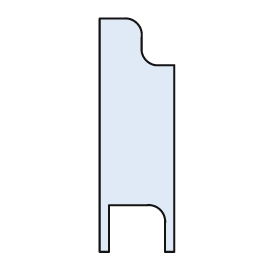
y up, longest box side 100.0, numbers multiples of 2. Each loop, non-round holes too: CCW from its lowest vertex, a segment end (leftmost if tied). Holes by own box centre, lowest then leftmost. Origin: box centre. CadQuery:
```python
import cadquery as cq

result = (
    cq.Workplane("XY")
    .moveTo(-16.0, -50.0)
    .lineTo(-12.0, -50.0)
    .lineTo(-12.0, -30.0)
    .lineTo(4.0, -30.0)
    .threePointArc((10.0, -32.0), (12.0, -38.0))
    .lineTo(12.0, -50.0)
    .lineTo(16.0, -50.0)
    .lineTo(16.0, 30.0)
    .lineTo(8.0, 30.0)
    .threePointArc((4.0, 32.0), (2.0, 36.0))
    .lineTo(2.0, 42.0)
    .threePointArc((0.0, 48.0), (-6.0, 50.0))
    .lineTo(-16.0, 50.0)
    .close()
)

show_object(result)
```